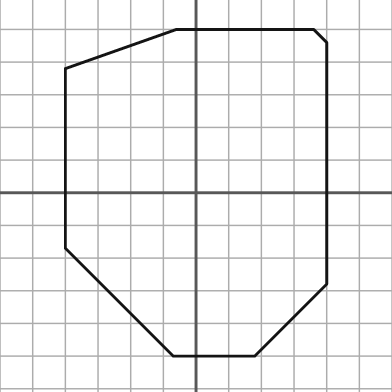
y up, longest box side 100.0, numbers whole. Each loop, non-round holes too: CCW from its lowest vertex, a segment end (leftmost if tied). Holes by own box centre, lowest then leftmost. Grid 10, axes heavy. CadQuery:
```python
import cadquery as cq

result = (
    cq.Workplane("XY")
    .moveTo(-7.0, -50.0)
    .lineTo(18.0, -50.0)
    .lineTo(40.0, -28.0)
    .lineTo(40.0, 46.0)
    .lineTo(36.0, 50.0)
    .lineTo(-6.0, 50.0)
    .lineTo(-40.0, 38.0)
    .lineTo(-40.0, -17.0)
    .close()
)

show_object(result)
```